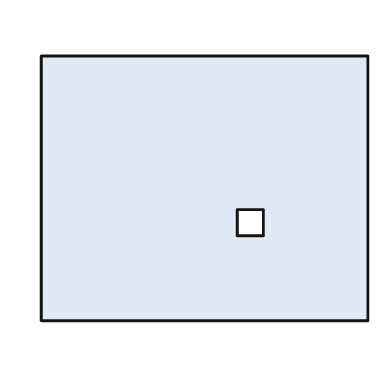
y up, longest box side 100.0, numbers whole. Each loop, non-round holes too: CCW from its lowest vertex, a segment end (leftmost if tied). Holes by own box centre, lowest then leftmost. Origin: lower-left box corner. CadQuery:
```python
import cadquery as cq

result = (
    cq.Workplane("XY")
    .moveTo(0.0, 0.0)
    .lineTo(100.0, 0.0)
    .lineTo(100.0, 81.0)
    .lineTo(0.0, 81.0)
    .close()
    .moveTo(60.0, 26.0)
    .lineTo(68.0, 26.0)
    .lineTo(68.0, 34.0)
    .lineTo(60.0, 34.0)
    .close()
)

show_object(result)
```